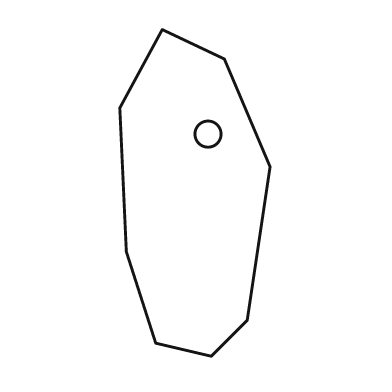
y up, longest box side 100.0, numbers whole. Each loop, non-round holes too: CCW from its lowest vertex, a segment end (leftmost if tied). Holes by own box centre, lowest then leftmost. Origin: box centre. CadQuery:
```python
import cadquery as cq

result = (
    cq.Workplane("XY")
    .moveTo(5.0, -50.0)
    .lineTo(16.0, -39.0)
    .lineTo(23.0, 8.0)
    .lineTo(9.0, 41.0)
    .lineTo(-10.0, 50.0)
    .lineTo(-23.0, 26.0)
    .lineTo(-21.0, -18.0)
    .lineTo(-12.0, -46.0)
    .close()
    .moveTo(4.0, 18.0)
    .circle(4.0)
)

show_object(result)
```